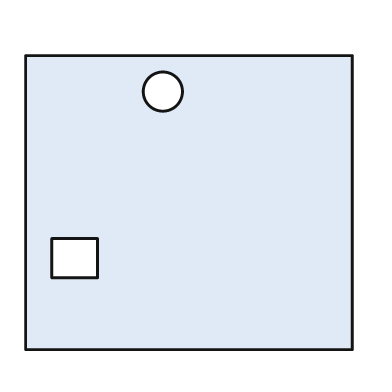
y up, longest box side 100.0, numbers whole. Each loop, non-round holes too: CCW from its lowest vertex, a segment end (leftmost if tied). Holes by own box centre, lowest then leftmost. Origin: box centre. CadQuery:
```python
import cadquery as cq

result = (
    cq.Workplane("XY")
    .moveTo(-50.0, -45.0)
    .lineTo(50.0, -45.0)
    .lineTo(50.0, 45.0)
    .lineTo(-50.0, 45.0)
    .close()
    .moveTo(-42.0, -23.0)
    .lineTo(-28.0, -23.0)
    .lineTo(-28.0, -11.0)
    .lineTo(-42.0, -11.0)
    .close()
    .moveTo(-8.0, 34.0)
    .circle(6.0)
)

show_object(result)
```